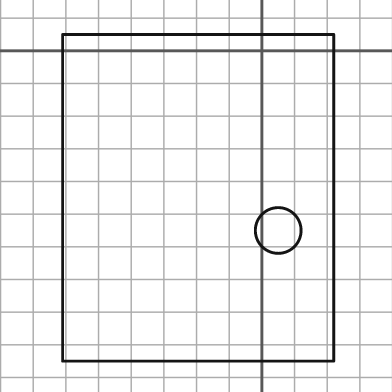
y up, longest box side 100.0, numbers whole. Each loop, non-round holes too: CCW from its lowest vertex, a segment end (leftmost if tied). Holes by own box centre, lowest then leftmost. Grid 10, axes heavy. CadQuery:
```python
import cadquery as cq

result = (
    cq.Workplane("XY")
    .moveTo(-61.0, -95.0)
    .lineTo(22.0, -95.0)
    .lineTo(22.0, 5.0)
    .lineTo(-61.0, 5.0)
    .close()
    .moveTo(5.0, -55.0)
    .circle(7.0)
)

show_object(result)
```